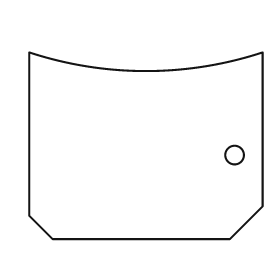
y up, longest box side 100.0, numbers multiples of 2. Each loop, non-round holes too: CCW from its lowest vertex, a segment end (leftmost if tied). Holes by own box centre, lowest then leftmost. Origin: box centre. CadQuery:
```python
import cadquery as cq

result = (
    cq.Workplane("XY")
    .moveTo(-40.0, -40.0)
    .lineTo(36.0, -40.0)
    .lineTo(50.0, -26.0)
    .lineTo(50.0, 40.0)
    .threePointArc((0.0, 32.0), (-50.0, 40.0))
    .lineTo(-50.0, -30.0)
    .close()
    .moveTo(38.0, -4.0)
    .circle(4.0)
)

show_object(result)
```